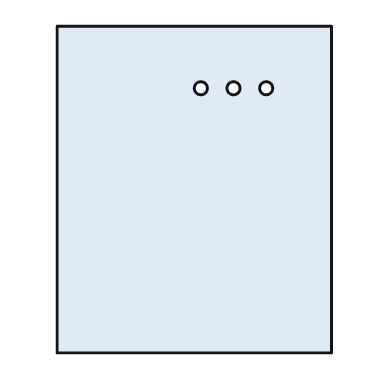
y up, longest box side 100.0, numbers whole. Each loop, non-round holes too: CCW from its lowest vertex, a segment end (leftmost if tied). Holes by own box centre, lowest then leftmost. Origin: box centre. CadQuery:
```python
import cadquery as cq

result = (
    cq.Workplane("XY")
    .moveTo(-42.0, -50.0)
    .lineTo(42.0, -50.0)
    .lineTo(42.0, 50.0)
    .lineTo(-42.0, 50.0)
    .close()
    .moveTo(2.0, 31.0)
    .circle(2.0)
    .moveTo(12.0, 31.0)
    .circle(2.0)
    .moveTo(22.0, 31.0)
    .circle(2.0)
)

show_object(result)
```